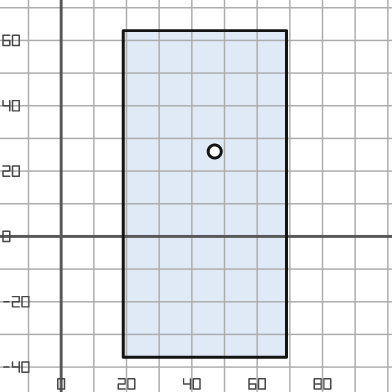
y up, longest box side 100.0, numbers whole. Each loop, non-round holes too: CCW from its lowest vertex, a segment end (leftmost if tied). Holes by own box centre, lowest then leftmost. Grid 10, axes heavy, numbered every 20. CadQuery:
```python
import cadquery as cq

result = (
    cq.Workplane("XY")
    .moveTo(19.0, -37.0)
    .lineTo(69.0, -37.0)
    .lineTo(69.0, 63.0)
    .lineTo(19.0, 63.0)
    .close()
    .moveTo(47.0, 26.0)
    .circle(2.0)
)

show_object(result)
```